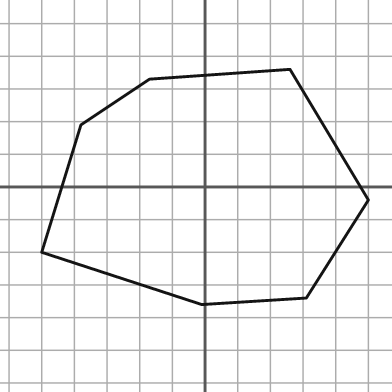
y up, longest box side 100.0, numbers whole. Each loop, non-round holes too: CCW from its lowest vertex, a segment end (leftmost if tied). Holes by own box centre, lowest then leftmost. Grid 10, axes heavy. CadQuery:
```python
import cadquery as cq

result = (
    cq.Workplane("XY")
    .moveTo(-1.0, -36.0)
    .lineTo(31.0, -34.0)
    .lineTo(50.0, -4.0)
    .lineTo(26.0, 36.0)
    .lineTo(-17.0, 33.0)
    .lineTo(-38.0, 19.0)
    .lineTo(-50.0, -20.0)
    .close()
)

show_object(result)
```